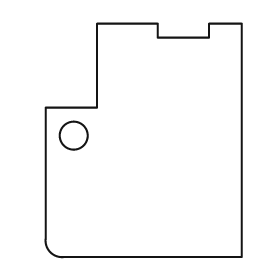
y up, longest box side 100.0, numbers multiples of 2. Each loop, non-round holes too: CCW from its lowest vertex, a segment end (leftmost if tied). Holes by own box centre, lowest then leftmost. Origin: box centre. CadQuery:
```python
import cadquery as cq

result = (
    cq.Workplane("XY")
    .moveTo(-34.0, -50.0)
    .lineTo(42.0, -50.0)
    .lineTo(42.0, 50.0)
    .lineTo(28.0, 50.0)
    .lineTo(28.0, 44.0)
    .lineTo(6.0, 44.0)
    .lineTo(6.0, 50.0)
    .lineTo(-20.0, 50.0)
    .lineTo(-20.0, 14.0)
    .lineTo(-42.0, 14.0)
    .lineTo(-42.0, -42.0)
    .threePointArc((-40.0, -48.0), (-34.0, -50.0))
    .close()
    .moveTo(-30.0, 2.0)
    .circle(6.0)
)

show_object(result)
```